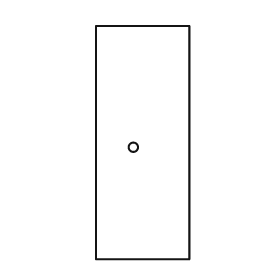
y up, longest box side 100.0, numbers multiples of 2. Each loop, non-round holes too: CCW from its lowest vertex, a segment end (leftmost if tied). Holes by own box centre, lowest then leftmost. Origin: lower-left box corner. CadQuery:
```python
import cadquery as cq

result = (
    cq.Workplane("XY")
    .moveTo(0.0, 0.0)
    .lineTo(40.0, 0.0)
    .lineTo(40.0, 100.0)
    .lineTo(0.0, 100.0)
    .close()
    .moveTo(16.0, 48.0)
    .circle(2.0)
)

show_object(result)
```